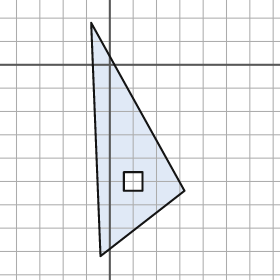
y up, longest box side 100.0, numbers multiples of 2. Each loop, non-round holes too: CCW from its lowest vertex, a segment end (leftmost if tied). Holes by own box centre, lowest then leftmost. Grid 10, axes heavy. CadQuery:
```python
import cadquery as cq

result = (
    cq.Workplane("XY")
    .moveTo(-4.0, -82.0)
    .lineTo(32.0, -54.0)
    .lineTo(-8.0, 18.0)
    .close()
    .moveTo(6.0, -54.0)
    .lineTo(14.0, -54.0)
    .lineTo(14.0, -46.0)
    .lineTo(6.0, -46.0)
    .close()
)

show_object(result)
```